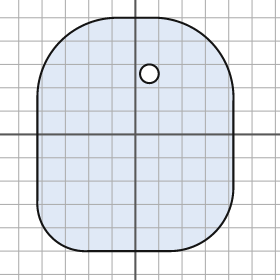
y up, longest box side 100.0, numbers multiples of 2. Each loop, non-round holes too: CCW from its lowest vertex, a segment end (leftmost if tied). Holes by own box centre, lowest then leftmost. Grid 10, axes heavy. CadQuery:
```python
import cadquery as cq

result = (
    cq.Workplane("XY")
    .moveTo(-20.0, -50.0)
    .lineTo(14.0, -50.0)
    .threePointArc((34.0, -42.0), (42.0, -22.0))
    .lineTo(42.0, 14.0)
    .threePointArc((32.0, 40.0), (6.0, 50.0))
    .lineTo(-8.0, 50.0)
    .threePointArc((-32.0, 40.0), (-42.0, 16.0))
    .lineTo(-42.0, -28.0)
    .threePointArc((-36.0, -44.0), (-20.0, -50.0))
    .close()
    .moveTo(6.0, 26.0)
    .circle(4.0)
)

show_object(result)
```